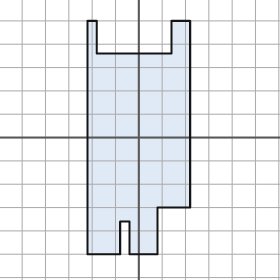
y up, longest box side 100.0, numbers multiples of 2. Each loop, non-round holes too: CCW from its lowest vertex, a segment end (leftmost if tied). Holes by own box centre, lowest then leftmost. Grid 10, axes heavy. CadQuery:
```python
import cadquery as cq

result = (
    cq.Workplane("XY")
    .moveTo(-22.0, -50.0)
    .lineTo(-8.0, -50.0)
    .lineTo(-8.0, -36.0)
    .lineTo(-4.0, -36.0)
    .lineTo(-4.0, -50.0)
    .lineTo(8.0, -50.0)
    .lineTo(8.0, -30.0)
    .lineTo(22.0, -30.0)
    .lineTo(22.0, 50.0)
    .lineTo(14.0, 50.0)
    .lineTo(14.0, 36.0)
    .lineTo(-18.0, 36.0)
    .lineTo(-18.0, 50.0)
    .lineTo(-22.0, 50.0)
    .close()
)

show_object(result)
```